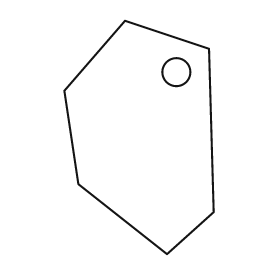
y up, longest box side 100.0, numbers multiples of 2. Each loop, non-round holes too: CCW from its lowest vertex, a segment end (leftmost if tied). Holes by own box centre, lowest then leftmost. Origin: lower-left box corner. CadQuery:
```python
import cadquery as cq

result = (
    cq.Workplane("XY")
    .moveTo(44.0, 0.0)
    .lineTo(64.0, 18.0)
    .lineTo(62.0, 88.0)
    .lineTo(26.0, 100.0)
    .lineTo(0.0, 70.0)
    .lineTo(6.0, 30.0)
    .close()
    .moveTo(48.0, 78.0)
    .circle(6.0)
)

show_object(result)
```